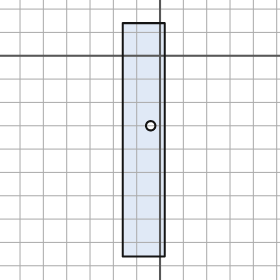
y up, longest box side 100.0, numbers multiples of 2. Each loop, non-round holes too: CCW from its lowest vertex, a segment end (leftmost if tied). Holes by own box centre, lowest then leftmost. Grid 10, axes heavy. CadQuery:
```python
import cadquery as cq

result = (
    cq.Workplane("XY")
    .moveTo(-16.0, -86.0)
    .lineTo(2.0, -86.0)
    .lineTo(2.0, 14.0)
    .lineTo(-16.0, 14.0)
    .close()
    .moveTo(-4.0, -30.0)
    .circle(2.0)
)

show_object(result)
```